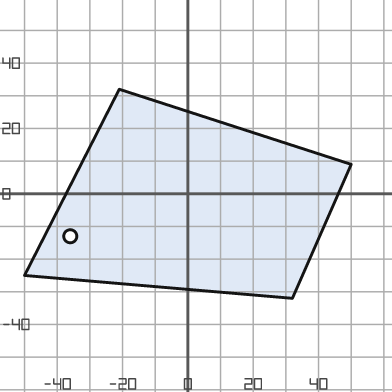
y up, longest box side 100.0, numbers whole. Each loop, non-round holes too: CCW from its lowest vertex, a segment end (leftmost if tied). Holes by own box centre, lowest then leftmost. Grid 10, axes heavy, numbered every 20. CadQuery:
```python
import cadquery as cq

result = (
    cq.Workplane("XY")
    .moveTo(32.0, -32.0)
    .lineTo(50.0, 9.0)
    .lineTo(-21.0, 32.0)
    .lineTo(-50.0, -25.0)
    .close()
    .moveTo(-36.0, -13.0)
    .circle(2.0)
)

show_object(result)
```